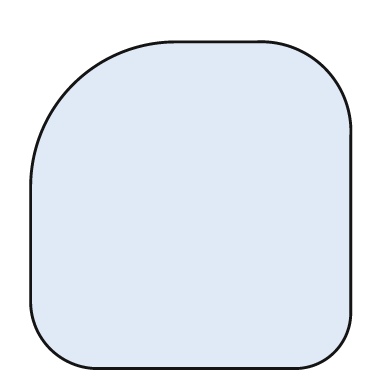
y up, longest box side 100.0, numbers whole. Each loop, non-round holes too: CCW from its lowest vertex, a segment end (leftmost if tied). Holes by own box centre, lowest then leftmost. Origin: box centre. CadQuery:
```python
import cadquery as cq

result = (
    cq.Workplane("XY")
    .moveTo(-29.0, -50.0)
    .lineTo(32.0, -50.0)
    .threePointArc((44.0, -45.0), (49.0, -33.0))
    .lineTo(49.0, 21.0)
    .threePointArc((41.0, 42.0), (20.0, 50.0))
    .lineTo(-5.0, 50.0)
    .threePointArc((-36.0, 37.0), (-49.0, 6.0))
    .lineTo(-49.0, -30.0)
    .threePointArc((-43.0, -44.0), (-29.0, -50.0))
    .close()
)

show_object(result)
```